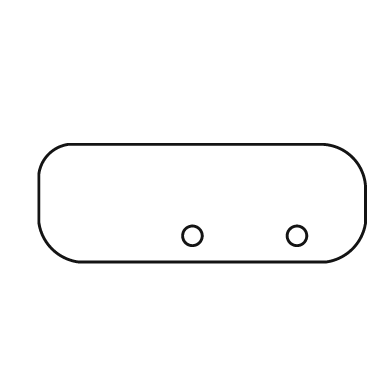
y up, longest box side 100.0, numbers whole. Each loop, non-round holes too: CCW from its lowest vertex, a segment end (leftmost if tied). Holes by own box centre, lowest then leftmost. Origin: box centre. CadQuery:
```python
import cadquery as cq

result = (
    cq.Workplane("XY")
    .moveTo(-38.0, -18.0)
    .lineTo(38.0, -18.0)
    .threePointArc((46.0, -14.0), (50.0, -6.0))
    .lineTo(50.0, 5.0)
    .threePointArc((46.0, 14.0), (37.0, 18.0))
    .lineTo(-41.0, 18.0)
    .threePointArc((-47.0, 15.0), (-50.0, 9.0))
    .lineTo(-50.0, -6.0)
    .threePointArc((-46.0, -14.0), (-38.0, -18.0))
    .close()
    .moveTo(-3.0, -10.0)
    .circle(3.0)
    .moveTo(29.0, -10.0)
    .circle(3.0)
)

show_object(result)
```